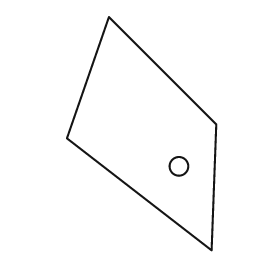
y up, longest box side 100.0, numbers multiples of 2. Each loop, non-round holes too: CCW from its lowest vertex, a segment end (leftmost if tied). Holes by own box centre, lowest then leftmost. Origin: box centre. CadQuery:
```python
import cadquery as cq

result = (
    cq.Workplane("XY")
    .moveTo(30.0, -50.0)
    .lineTo(32.0, 4.0)
    .lineTo(-14.0, 50.0)
    .lineTo(-32.0, -2.0)
    .close()
    .moveTo(16.0, -14.0)
    .circle(4.0)
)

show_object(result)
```